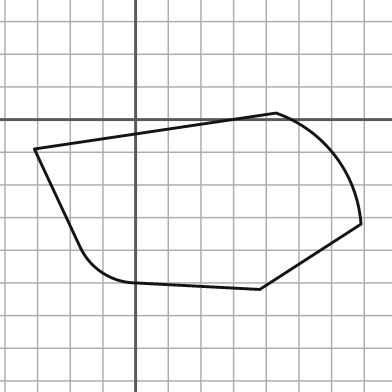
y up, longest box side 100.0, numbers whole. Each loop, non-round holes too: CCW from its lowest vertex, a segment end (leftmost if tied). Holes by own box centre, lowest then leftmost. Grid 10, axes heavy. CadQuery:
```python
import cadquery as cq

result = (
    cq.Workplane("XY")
    .moveTo(38.0, -52.0)
    .lineTo(69.0, -32.0)
    .threePointArc((61.0, -11.0), (43.0, 2.0))
    .lineTo(-31.0, -9.0)
    .lineTo(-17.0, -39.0)
    .threePointArc((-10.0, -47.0), (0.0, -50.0))
    .close()
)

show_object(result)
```